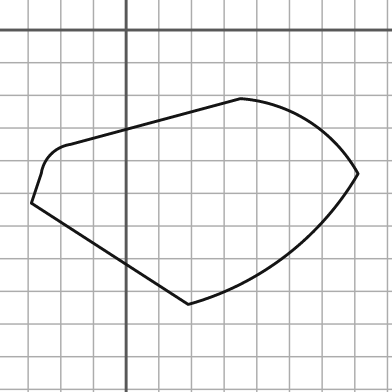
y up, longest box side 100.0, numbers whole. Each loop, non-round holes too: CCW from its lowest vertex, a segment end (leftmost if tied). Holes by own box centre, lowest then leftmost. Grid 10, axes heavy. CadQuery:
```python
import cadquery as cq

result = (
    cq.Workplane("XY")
    .moveTo(19.0, -84.0)
    .threePointArc((49.0, -69.0), (71.0, -44.0))
    .threePointArc((56.0, -28.0), (35.0, -21.0))
    .lineTo(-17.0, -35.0)
    .threePointArc((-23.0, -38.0), (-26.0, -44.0))
    .lineTo(-29.0, -53.0)
    .close()
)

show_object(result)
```